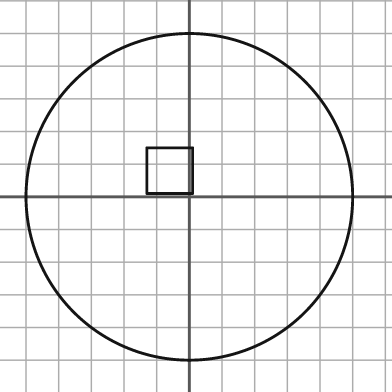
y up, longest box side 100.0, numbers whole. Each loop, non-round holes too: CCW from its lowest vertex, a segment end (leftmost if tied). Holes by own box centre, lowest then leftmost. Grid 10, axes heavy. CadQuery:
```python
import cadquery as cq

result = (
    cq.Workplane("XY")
    .moveTo(0.0, 0.0)
    .circle(50.0)
    .moveTo(-13.0, 1.0)
    .lineTo(1.0, 1.0)
    .lineTo(1.0, 15.0)
    .lineTo(-13.0, 15.0)
    .close()
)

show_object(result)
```